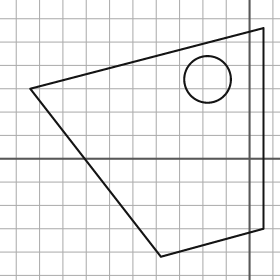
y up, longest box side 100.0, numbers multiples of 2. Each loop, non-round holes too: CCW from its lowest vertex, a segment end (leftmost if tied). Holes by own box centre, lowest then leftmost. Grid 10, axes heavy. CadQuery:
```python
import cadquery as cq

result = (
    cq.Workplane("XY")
    .moveTo(-38.0, -42.0)
    .lineTo(6.0, -30.0)
    .lineTo(6.0, 56.0)
    .lineTo(-94.0, 30.0)
    .close()
    .moveTo(-18.0, 34.0)
    .circle(10.0)
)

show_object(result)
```